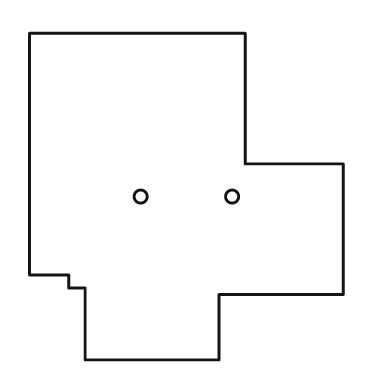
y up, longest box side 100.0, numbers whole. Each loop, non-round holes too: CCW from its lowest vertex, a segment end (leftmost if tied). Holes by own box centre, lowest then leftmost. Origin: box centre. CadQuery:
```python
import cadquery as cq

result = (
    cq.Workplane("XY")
    .moveTo(-31.0, -50.0)
    .lineTo(10.0, -50.0)
    .lineTo(10.0, -30.0)
    .lineTo(48.0, -30.0)
    .lineTo(48.0, 10.0)
    .lineTo(18.0, 10.0)
    .lineTo(18.0, 50.0)
    .lineTo(-48.0, 50.0)
    .lineTo(-48.0, -24.0)
    .lineTo(-36.0, -24.0)
    .lineTo(-36.0, -28.0)
    .lineTo(-31.0, -28.0)
    .close()
    .moveTo(-14.0, 0.0)
    .circle(2.0)
    .moveTo(14.0, 0.0)
    .circle(2.0)
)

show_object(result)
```